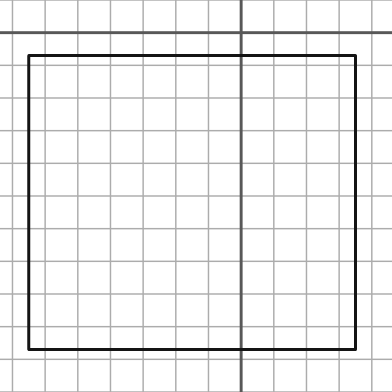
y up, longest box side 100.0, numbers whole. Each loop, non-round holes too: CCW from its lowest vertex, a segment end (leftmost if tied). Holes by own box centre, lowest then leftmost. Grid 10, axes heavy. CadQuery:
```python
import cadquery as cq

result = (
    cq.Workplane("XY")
    .moveTo(-65.0, -97.0)
    .lineTo(35.0, -97.0)
    .lineTo(35.0, -7.0)
    .lineTo(-65.0, -7.0)
    .close()
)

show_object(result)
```